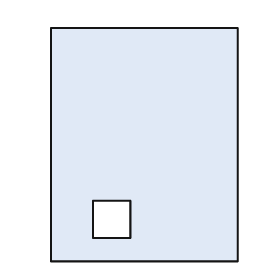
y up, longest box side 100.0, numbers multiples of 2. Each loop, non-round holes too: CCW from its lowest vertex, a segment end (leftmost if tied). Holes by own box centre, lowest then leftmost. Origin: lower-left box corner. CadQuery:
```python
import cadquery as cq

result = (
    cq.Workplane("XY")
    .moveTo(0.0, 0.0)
    .lineTo(80.0, 0.0)
    .lineTo(80.0, 100.0)
    .lineTo(0.0, 100.0)
    .close()
    .moveTo(18.0, 10.0)
    .lineTo(34.0, 10.0)
    .lineTo(34.0, 26.0)
    .lineTo(18.0, 26.0)
    .close()
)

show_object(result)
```